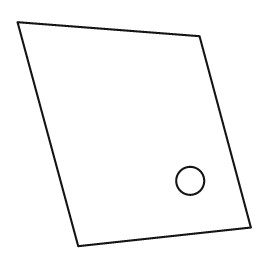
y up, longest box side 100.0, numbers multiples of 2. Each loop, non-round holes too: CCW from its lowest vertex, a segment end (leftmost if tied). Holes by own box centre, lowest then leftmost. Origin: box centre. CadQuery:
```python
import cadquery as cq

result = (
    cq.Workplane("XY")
    .moveTo(-24.0, -48.0)
    .lineTo(50.0, -40.0)
    .lineTo(28.0, 42.0)
    .lineTo(-50.0, 48.0)
    .close()
    .moveTo(24.0, -20.0)
    .circle(6.0)
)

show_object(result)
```